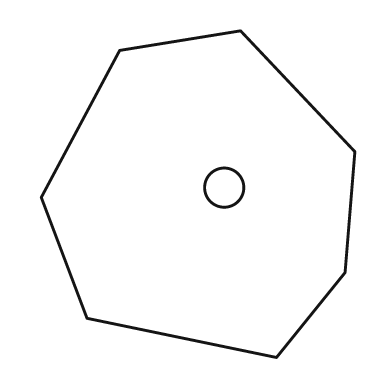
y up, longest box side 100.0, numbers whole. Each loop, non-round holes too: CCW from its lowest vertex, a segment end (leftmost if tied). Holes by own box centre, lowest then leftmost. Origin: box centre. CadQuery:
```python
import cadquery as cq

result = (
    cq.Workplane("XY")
    .moveTo(24.0, -50.0)
    .lineTo(45.0, -24.0)
    .lineTo(48.0, 13.0)
    .lineTo(13.0, 50.0)
    .lineTo(-24.0, 44.0)
    .lineTo(-48.0, -1.0)
    .lineTo(-34.0, -38.0)
    .close()
    .moveTo(8.0, 2.0)
    .circle(6.0)
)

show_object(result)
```